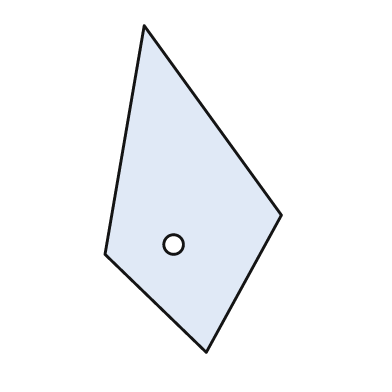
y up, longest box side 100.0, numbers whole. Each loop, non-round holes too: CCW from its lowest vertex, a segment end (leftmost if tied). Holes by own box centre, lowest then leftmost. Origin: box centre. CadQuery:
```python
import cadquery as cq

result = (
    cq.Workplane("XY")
    .moveTo(4.0, -50.0)
    .lineTo(27.0, -8.0)
    .lineTo(-15.0, 50.0)
    .lineTo(-27.0, -20.0)
    .close()
    .moveTo(-6.0, -17.0)
    .circle(3.0)
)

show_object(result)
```